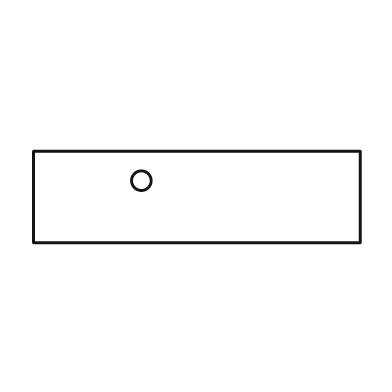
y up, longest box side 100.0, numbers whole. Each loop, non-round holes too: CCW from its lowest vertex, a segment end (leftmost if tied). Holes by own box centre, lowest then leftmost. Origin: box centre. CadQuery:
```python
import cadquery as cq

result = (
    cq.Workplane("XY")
    .moveTo(-50.0, -14.0)
    .lineTo(50.0, -14.0)
    .lineTo(50.0, 14.0)
    .lineTo(-50.0, 14.0)
    .close()
    .moveTo(-17.0, 5.0)
    .circle(3.0)
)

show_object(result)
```